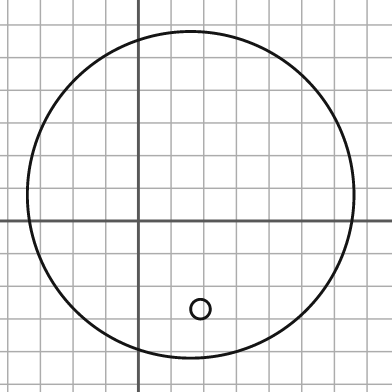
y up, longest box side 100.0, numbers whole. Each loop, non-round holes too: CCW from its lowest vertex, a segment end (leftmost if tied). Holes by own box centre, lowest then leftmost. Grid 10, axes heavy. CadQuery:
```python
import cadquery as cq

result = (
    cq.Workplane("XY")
    .moveTo(16.0, 8.0)
    .circle(50.0)
    .moveTo(19.0, -27.0)
    .circle(3.0)
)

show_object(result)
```